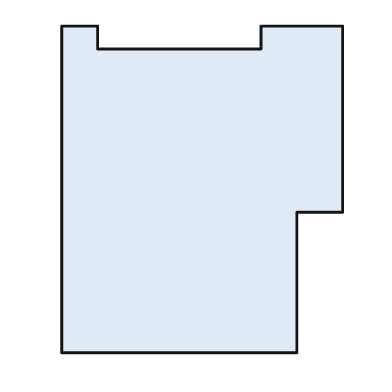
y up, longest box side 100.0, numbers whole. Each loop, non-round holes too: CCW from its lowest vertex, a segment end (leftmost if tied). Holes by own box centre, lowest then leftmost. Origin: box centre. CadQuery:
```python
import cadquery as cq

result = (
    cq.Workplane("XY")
    .moveTo(-43.0, -50.0)
    .lineTo(29.0, -50.0)
    .lineTo(29.0, -7.0)
    .lineTo(43.0, -7.0)
    .lineTo(43.0, 50.0)
    .lineTo(18.0, 50.0)
    .lineTo(18.0, 43.0)
    .lineTo(-32.0, 43.0)
    .lineTo(-32.0, 50.0)
    .lineTo(-43.0, 50.0)
    .close()
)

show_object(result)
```